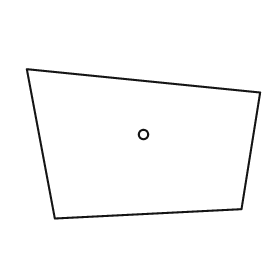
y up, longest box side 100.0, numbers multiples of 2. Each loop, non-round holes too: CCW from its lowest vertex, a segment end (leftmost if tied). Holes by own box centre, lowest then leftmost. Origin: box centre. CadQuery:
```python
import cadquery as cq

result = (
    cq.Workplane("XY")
    .moveTo(-38.0, -32.0)
    .lineTo(42.0, -28.0)
    .lineTo(50.0, 22.0)
    .lineTo(-50.0, 32.0)
    .close()
    .moveTo(0.0, 4.0)
    .circle(2.0)
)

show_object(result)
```